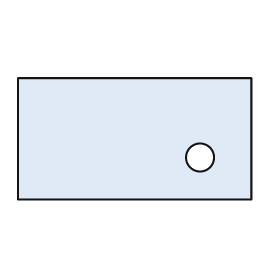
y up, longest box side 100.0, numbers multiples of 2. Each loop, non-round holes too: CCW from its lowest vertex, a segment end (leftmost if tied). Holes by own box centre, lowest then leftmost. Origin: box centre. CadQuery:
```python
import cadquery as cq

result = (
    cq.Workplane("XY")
    .moveTo(-50.0, -26.0)
    .lineTo(50.0, -26.0)
    .lineTo(50.0, 26.0)
    .lineTo(-50.0, 26.0)
    .close()
    .moveTo(28.0, -8.0)
    .circle(6.0)
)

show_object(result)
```